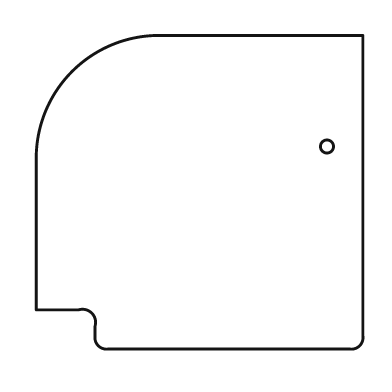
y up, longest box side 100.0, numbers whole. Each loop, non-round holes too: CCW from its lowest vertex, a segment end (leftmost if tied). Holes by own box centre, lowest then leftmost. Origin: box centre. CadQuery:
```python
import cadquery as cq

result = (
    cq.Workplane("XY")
    .moveTo(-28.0, -48.0)
    .lineTo(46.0, -48.0)
    .threePointArc((49.0, -47.0), (50.0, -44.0))
    .lineTo(50.0, 48.0)
    .lineTo(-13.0, 48.0)
    .threePointArc((-39.0, 37.0), (-50.0, 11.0))
    .lineTo(-50.0, -36.0)
    .lineTo(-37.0, -36.0)
    .threePointArc((-33.0, -37.0), (-32.0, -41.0))
    .lineTo(-32.0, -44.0)
    .threePointArc((-31.0, -47.0), (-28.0, -48.0))
    .close()
    .moveTo(39.0, 14.0)
    .circle(2.0)
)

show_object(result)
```